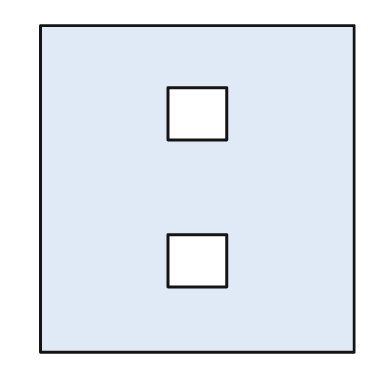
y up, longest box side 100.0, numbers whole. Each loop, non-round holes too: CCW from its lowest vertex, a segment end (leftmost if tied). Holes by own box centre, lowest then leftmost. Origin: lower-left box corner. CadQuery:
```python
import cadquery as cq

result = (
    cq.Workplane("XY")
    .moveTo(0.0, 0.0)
    .lineTo(96.0, 0.0)
    .lineTo(96.0, 100.0)
    .lineTo(0.0, 100.0)
    .close()
    .moveTo(39.0, 20.0)
    .lineTo(57.0, 20.0)
    .lineTo(57.0, 36.0)
    .lineTo(39.0, 36.0)
    .close()
    .moveTo(39.0, 65.0)
    .lineTo(57.0, 65.0)
    .lineTo(57.0, 81.0)
    .lineTo(39.0, 81.0)
    .close()
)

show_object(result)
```